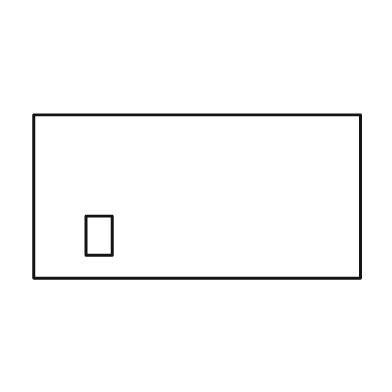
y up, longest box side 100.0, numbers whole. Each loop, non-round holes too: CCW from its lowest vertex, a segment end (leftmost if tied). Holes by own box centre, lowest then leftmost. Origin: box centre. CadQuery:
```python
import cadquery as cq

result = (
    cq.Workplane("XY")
    .moveTo(-50.0, -25.0)
    .lineTo(50.0, -25.0)
    .lineTo(50.0, 25.0)
    .lineTo(-50.0, 25.0)
    .close()
    .moveTo(-34.0, -18.0)
    .lineTo(-26.0, -18.0)
    .lineTo(-26.0, -6.0)
    .lineTo(-34.0, -6.0)
    .close()
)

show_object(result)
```